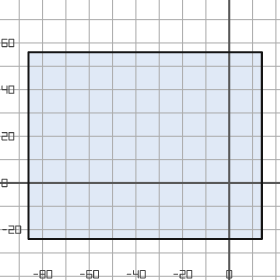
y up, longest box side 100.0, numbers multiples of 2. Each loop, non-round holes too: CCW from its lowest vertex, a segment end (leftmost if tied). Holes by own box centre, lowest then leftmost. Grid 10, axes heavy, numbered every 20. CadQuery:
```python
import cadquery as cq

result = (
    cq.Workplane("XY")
    .moveTo(-86.0, -24.0)
    .lineTo(14.0, -24.0)
    .lineTo(14.0, 56.0)
    .lineTo(-86.0, 56.0)
    .close()
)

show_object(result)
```